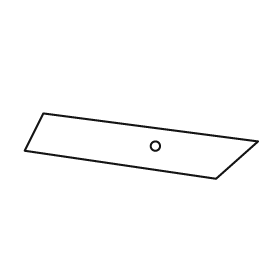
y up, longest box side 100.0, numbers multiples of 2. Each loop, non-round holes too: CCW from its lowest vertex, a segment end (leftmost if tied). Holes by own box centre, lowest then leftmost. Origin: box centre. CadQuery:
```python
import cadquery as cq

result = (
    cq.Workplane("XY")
    .moveTo(32.0, -14.0)
    .lineTo(50.0, 2.0)
    .lineTo(-42.0, 14.0)
    .lineTo(-50.0, -2.0)
    .close()
    .moveTo(6.0, 0.0)
    .circle(2.0)
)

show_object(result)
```